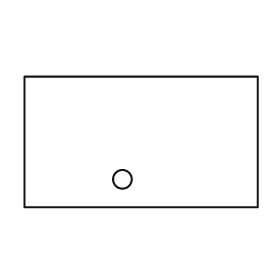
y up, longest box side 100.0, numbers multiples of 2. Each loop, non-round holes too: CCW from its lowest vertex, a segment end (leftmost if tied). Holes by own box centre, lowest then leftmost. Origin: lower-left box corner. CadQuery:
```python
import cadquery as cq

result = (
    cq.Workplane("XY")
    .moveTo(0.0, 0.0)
    .lineTo(100.0, 0.0)
    .lineTo(100.0, 56.0)
    .lineTo(0.0, 56.0)
    .close()
    .moveTo(42.0, 12.0)
    .circle(4.0)
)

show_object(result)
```